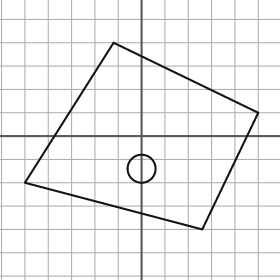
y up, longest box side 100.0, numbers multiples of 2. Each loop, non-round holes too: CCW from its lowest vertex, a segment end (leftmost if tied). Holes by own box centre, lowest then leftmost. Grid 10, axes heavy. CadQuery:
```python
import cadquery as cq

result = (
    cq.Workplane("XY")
    .moveTo(26.0, -40.0)
    .lineTo(50.0, 10.0)
    .lineTo(-12.0, 40.0)
    .lineTo(-50.0, -20.0)
    .close()
    .moveTo(0.0, -14.0)
    .circle(6.0)
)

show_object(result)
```